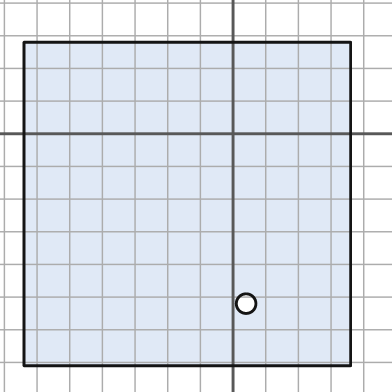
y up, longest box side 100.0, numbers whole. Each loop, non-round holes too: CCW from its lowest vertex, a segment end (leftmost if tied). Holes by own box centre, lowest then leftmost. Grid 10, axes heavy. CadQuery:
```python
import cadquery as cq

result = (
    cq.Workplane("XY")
    .moveTo(-64.0, -71.0)
    .lineTo(36.0, -71.0)
    .lineTo(36.0, 28.0)
    .lineTo(-64.0, 28.0)
    .close()
    .moveTo(4.0, -52.0)
    .circle(3.0)
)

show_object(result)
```